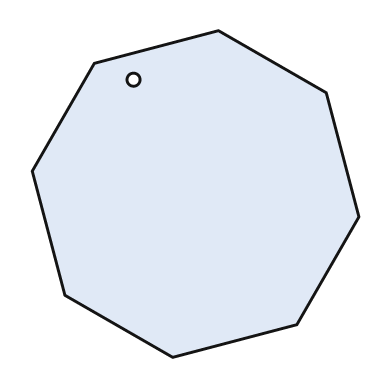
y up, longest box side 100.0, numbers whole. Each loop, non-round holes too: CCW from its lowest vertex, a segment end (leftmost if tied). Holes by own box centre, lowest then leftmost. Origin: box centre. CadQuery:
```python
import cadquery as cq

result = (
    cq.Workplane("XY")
    .moveTo(-7.0, -50.0)
    .lineTo(31.0, -40.0)
    .lineTo(50.0, -7.0)
    .lineTo(40.0, 31.0)
    .lineTo(7.0, 50.0)
    .lineTo(-31.0, 40.0)
    .lineTo(-50.0, 7.0)
    .lineTo(-40.0, -31.0)
    .close()
    .moveTo(-19.0, 35.0)
    .circle(2.0)
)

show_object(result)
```